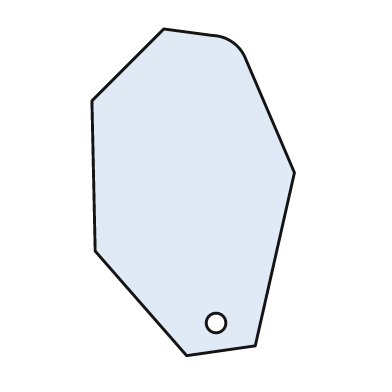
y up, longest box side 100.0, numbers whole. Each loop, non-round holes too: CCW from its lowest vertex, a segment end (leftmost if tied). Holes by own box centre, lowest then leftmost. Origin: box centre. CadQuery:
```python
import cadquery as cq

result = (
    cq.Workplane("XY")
    .moveTo(-2.0, -50.0)
    .lineTo(19.0, -47.0)
    .lineTo(31.0, 6.0)
    .lineTo(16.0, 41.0)
    .threePointArc((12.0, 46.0), (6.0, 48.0))
    .lineTo(-9.0, 50.0)
    .lineTo(-31.0, 28.0)
    .lineTo(-30.0, -18.0)
    .close()
    .moveTo(7.0, -40.0)
    .circle(3.0)
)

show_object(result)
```